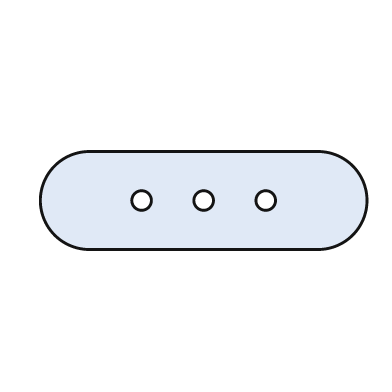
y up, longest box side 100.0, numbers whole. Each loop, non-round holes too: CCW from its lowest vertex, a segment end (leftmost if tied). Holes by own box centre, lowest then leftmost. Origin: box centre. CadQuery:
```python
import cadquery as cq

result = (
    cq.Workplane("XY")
    .moveTo(-35.0, -15.0)
    .lineTo(35.0, -15.0)
    .threePointArc((50.0, 0.0), (35.0, 15.0))
    .lineTo(-35.0, 15.0)
    .threePointArc((-50.0, 0.0), (-35.0, -15.0))
    .close()
    .moveTo(-19.0, 0.0)
    .circle(3.0)
    .moveTo(0.0, 0.0)
    .circle(3.0)
    .moveTo(19.0, 0.0)
    .circle(3.0)
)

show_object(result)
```